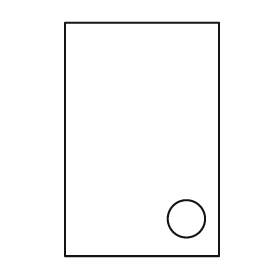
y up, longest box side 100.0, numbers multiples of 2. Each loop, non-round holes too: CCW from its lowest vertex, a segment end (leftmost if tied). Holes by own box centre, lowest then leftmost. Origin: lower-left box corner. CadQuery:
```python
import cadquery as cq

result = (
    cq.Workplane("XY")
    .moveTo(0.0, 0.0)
    .lineTo(66.0, 0.0)
    .lineTo(66.0, 100.0)
    .lineTo(0.0, 100.0)
    .close()
    .moveTo(52.0, 16.0)
    .circle(8.0)
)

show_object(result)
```